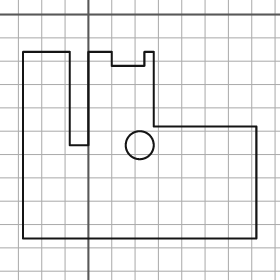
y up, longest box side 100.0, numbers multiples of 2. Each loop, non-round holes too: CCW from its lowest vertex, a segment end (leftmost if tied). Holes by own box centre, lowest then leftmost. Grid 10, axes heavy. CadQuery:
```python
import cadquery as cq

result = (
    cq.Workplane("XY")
    .moveTo(-28.0, -96.0)
    .lineTo(72.0, -96.0)
    .lineTo(72.0, -48.0)
    .lineTo(28.0, -48.0)
    .lineTo(28.0, -16.0)
    .lineTo(24.0, -16.0)
    .lineTo(24.0, -22.0)
    .lineTo(10.0, -22.0)
    .lineTo(10.0, -16.0)
    .lineTo(0.0, -16.0)
    .lineTo(0.0, -56.0)
    .lineTo(-8.0, -56.0)
    .lineTo(-8.0, -16.0)
    .lineTo(-28.0, -16.0)
    .close()
    .moveTo(22.0, -56.0)
    .circle(6.0)
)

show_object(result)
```